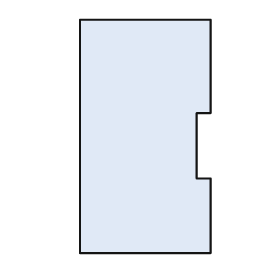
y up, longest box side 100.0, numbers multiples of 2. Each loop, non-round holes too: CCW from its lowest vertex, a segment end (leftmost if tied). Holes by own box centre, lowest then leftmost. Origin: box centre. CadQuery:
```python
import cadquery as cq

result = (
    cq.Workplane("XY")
    .moveTo(-28.0, -50.0)
    .lineTo(28.0, -50.0)
    .lineTo(28.0, -18.0)
    .lineTo(22.0, -18.0)
    .lineTo(22.0, 10.0)
    .lineTo(28.0, 10.0)
    .lineTo(28.0, 50.0)
    .lineTo(-28.0, 50.0)
    .close()
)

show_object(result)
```